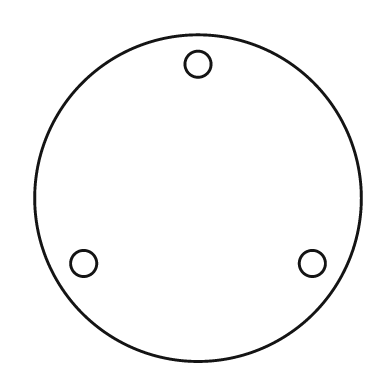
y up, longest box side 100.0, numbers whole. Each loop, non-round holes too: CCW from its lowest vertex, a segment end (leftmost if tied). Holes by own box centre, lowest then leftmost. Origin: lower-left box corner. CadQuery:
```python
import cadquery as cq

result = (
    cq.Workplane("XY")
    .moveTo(50.0, 50.0)
    .circle(50.0)
    .moveTo(15.0, 30.0)
    .circle(4.0)
    .moveTo(85.0, 30.0)
    .circle(4.0)
    .moveTo(50.0, 91.0)
    .circle(4.0)
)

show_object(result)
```